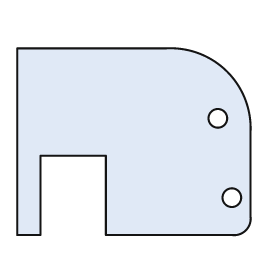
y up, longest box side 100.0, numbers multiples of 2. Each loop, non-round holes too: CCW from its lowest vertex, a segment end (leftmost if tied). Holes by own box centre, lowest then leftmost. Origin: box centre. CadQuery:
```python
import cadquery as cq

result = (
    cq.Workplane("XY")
    .moveTo(-50.0, -40.0)
    .lineTo(-40.0, -40.0)
    .lineTo(-40.0, -6.0)
    .lineTo(-12.0, -6.0)
    .lineTo(-12.0, -40.0)
    .lineTo(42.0, -40.0)
    .threePointArc((48.0, -38.0), (50.0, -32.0))
    .lineTo(50.0, 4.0)
    .threePointArc((40.0, 30.0), (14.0, 40.0))
    .lineTo(-50.0, 40.0)
    .close()
    .moveTo(42.0, -24.0)
    .circle(4.0)
    .moveTo(36.0, 10.0)
    .circle(4.0)
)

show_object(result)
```